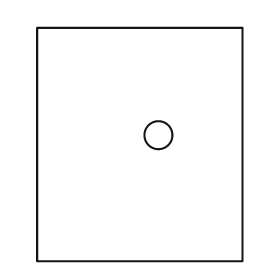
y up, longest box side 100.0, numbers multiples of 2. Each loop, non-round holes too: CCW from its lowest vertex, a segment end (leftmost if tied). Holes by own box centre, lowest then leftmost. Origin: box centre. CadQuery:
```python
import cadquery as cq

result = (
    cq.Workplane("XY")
    .moveTo(-44.0, -50.0)
    .lineTo(44.0, -50.0)
    .lineTo(44.0, 50.0)
    .lineTo(-44.0, 50.0)
    .close()
    .moveTo(8.0, 4.0)
    .circle(6.0)
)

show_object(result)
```